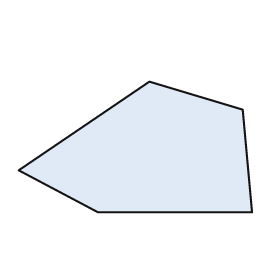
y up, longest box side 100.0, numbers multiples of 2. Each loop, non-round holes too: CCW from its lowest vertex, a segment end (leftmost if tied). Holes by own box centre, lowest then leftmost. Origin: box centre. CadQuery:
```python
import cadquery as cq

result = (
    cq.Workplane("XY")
    .moveTo(-16.0, -28.0)
    .lineTo(50.0, -28.0)
    .lineTo(46.0, 16.0)
    .lineTo(6.0, 28.0)
    .lineTo(-50.0, -10.0)
    .close()
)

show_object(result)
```